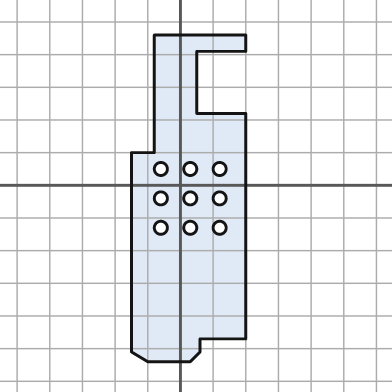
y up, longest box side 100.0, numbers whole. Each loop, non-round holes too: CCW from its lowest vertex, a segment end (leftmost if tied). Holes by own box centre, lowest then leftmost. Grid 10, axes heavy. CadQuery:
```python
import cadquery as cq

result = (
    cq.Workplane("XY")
    .moveTo(-10.0, -54.0)
    .lineTo(3.0, -54.0)
    .lineTo(6.0, -51.0)
    .lineTo(6.0, -47.0)
    .lineTo(20.0, -47.0)
    .lineTo(20.0, 22.0)
    .lineTo(5.0, 22.0)
    .lineTo(5.0, 41.0)
    .lineTo(20.0, 41.0)
    .lineTo(20.0, 46.0)
    .lineTo(-8.0, 46.0)
    .lineTo(-8.0, 10.0)
    .lineTo(-15.0, 10.0)
    .lineTo(-15.0, -51.0)
    .close()
    .moveTo(-6.0, -13.0)
    .circle(2.0)
    .moveTo(3.0, -13.0)
    .circle(2.0)
    .moveTo(12.0, -13.0)
    .circle(2.0)
    .moveTo(-6.0, -4.0)
    .circle(2.0)
    .moveTo(3.0, -4.0)
    .circle(2.0)
    .moveTo(12.0, -4.0)
    .circle(2.0)
    .moveTo(-6.0, 5.0)
    .circle(2.0)
    .moveTo(3.0, 5.0)
    .circle(2.0)
    .moveTo(12.0, 5.0)
    .circle(2.0)
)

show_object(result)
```